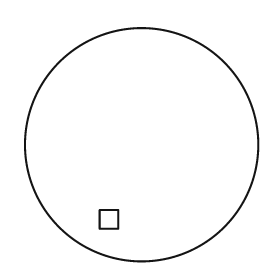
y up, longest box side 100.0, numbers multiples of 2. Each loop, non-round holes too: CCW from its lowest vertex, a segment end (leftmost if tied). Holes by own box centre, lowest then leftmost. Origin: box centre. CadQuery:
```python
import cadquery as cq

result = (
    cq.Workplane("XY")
    .moveTo(0.0, 0.0)
    .circle(50.0)
    .moveTo(-18.0, -36.0)
    .lineTo(-10.0, -36.0)
    .lineTo(-10.0, -28.0)
    .lineTo(-18.0, -28.0)
    .close()
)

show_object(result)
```